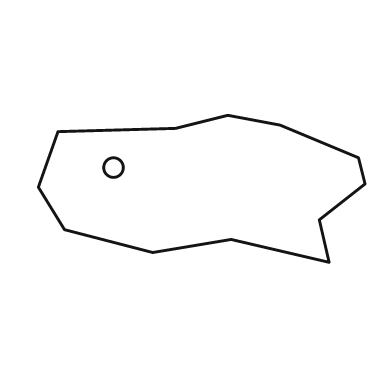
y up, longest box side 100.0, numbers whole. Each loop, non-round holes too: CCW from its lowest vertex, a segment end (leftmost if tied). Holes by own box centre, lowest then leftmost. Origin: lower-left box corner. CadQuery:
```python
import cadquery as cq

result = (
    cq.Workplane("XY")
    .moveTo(89.0, 0.0)
    .lineTo(86.0, 13.0)
    .lineTo(100.0, 24.0)
    .lineTo(98.0, 32.0)
    .lineTo(74.0, 42.0)
    .lineTo(58.0, 45.0)
    .lineTo(42.0, 41.0)
    .lineTo(6.0, 40.0)
    .lineTo(0.0, 23.0)
    .lineTo(8.0, 10.0)
    .lineTo(35.0, 3.0)
    .lineTo(59.0, 7.0)
    .close()
    .moveTo(23.0, 29.0)
    .circle(3.0)
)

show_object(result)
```